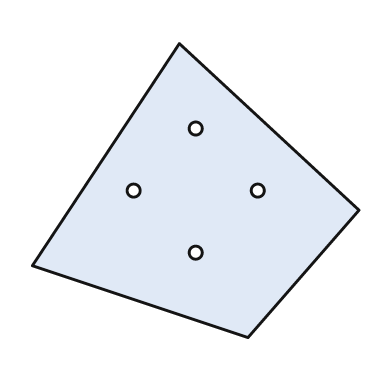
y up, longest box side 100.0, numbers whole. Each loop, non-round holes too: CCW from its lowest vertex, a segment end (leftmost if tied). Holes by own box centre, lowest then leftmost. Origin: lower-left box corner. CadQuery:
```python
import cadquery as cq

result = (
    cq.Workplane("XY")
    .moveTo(66.0, 0.0)
    .lineTo(100.0, 39.0)
    .lineTo(45.0, 90.0)
    .lineTo(0.0, 22.0)
    .close()
    .moveTo(50.0, 26.0)
    .circle(2.0)
    .moveTo(31.0, 45.0)
    .circle(2.0)
    .moveTo(69.0, 45.0)
    .circle(2.0)
    .moveTo(50.0, 64.0)
    .circle(2.0)
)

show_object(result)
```